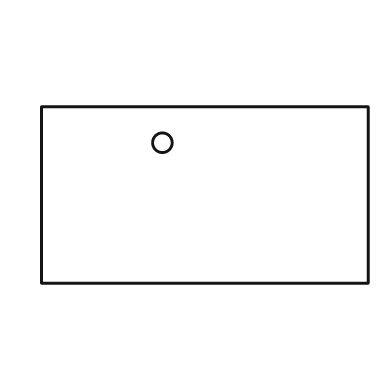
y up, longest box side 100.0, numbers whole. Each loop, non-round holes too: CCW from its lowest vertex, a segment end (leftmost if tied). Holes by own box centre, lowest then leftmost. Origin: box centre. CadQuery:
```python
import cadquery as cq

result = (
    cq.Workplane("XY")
    .moveTo(-50.0, -27.0)
    .lineTo(50.0, -27.0)
    .lineTo(50.0, 27.0)
    .lineTo(-50.0, 27.0)
    .close()
    .moveTo(-13.0, 16.0)
    .circle(3.0)
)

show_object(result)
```